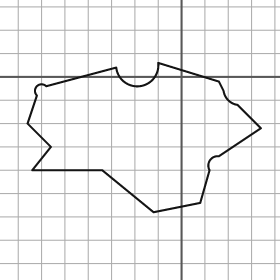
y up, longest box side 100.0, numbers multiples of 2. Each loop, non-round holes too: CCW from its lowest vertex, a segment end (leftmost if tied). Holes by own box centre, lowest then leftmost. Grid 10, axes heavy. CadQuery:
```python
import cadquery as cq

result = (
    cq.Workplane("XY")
    .moveTo(-12.0, -58.0)
    .lineTo(8.0, -54.0)
    .lineTo(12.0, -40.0)
    .threePointArc((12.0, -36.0), (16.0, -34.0))
    .lineTo(34.0, -22.0)
    .lineTo(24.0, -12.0)
    .threePointArc((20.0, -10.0), (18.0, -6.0))
    .lineTo(16.0, -2.0)
    .lineTo(-10.0, 6.0)
    .threePointArc((-18.0, -4.0), (-28.0, 4.0))
    .lineTo(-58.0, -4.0)
    .threePointArc((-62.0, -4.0), (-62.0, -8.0))
    .lineTo(-66.0, -20.0)
    .lineTo(-56.0, -30.0)
    .lineTo(-64.0, -40.0)
    .lineTo(-34.0, -40.0)
    .close()
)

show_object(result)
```